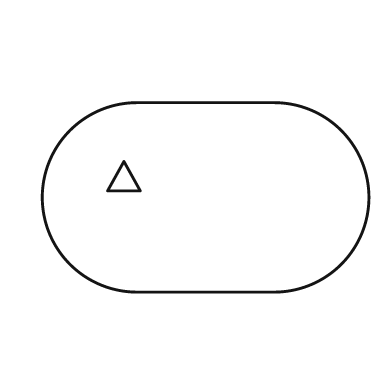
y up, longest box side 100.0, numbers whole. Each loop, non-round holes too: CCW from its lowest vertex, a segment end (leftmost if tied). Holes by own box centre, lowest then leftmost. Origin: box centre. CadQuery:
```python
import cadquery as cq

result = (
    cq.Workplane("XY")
    .moveTo(-21.0, -29.0)
    .lineTo(21.0, -29.0)
    .threePointArc((50.0, 0.0), (21.0, 29.0))
    .lineTo(-21.0, 29.0)
    .threePointArc((-50.0, 0.0), (-21.0, -29.0))
    .close()
    .moveTo(-30.0, 2.0)
    .lineTo(-20.0, 2.0)
    .lineTo(-25.0, 11.0)
    .close()
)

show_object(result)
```